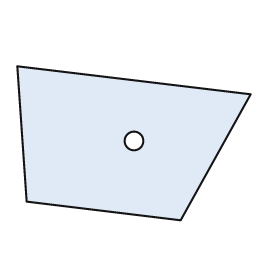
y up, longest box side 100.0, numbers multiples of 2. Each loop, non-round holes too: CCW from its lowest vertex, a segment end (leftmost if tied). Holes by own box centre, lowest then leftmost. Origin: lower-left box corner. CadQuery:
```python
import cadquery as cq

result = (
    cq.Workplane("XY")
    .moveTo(70.0, 0.0)
    .lineTo(100.0, 54.0)
    .lineTo(0.0, 66.0)
    .lineTo(4.0, 8.0)
    .close()
    .moveTo(50.0, 34.0)
    .circle(4.0)
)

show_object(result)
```